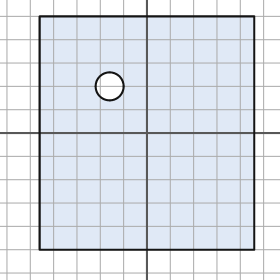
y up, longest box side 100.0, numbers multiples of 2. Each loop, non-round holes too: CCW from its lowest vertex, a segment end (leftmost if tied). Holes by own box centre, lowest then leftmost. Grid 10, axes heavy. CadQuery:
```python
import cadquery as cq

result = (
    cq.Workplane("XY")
    .moveTo(-46.0, -50.0)
    .lineTo(46.0, -50.0)
    .lineTo(46.0, 50.0)
    .lineTo(-46.0, 50.0)
    .close()
    .moveTo(-16.0, 20.0)
    .circle(6.0)
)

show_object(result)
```